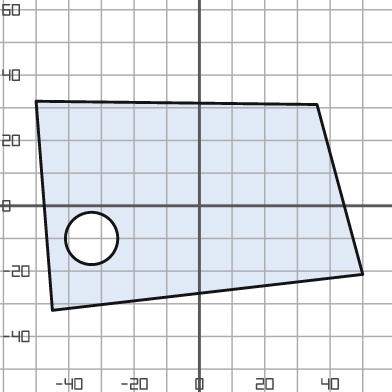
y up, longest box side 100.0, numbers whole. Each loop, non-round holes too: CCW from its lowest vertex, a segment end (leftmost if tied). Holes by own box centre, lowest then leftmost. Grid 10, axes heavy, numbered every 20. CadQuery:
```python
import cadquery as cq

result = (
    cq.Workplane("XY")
    .moveTo(-45.0, -32.0)
    .lineTo(50.0, -21.0)
    .lineTo(36.0, 31.0)
    .lineTo(-50.0, 32.0)
    .close()
    .moveTo(-33.0, -10.0)
    .circle(8.0)
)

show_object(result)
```